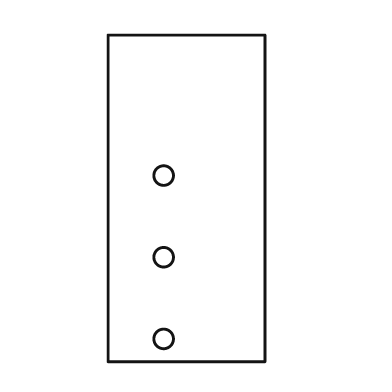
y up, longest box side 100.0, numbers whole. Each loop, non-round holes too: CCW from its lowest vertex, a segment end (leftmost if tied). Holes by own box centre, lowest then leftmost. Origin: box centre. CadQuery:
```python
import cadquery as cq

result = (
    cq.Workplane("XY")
    .moveTo(-24.0, -50.0)
    .lineTo(24.0, -50.0)
    .lineTo(24.0, 50.0)
    .lineTo(-24.0, 50.0)
    .close()
    .moveTo(-7.0, -43.0)
    .circle(3.0)
    .moveTo(-7.0, -18.0)
    .circle(3.0)
    .moveTo(-7.0, 7.0)
    .circle(3.0)
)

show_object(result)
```